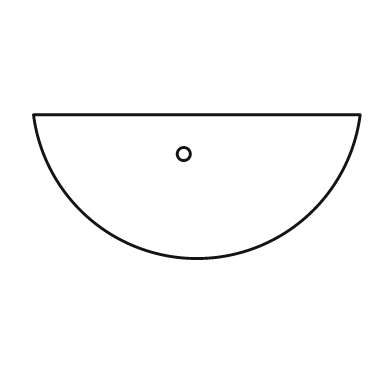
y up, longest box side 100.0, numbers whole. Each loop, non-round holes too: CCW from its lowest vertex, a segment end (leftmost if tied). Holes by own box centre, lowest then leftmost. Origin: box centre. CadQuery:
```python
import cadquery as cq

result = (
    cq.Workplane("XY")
    .moveTo(-50.0, 22.0)
    .threePointArc((0.0, -22.0), (50.0, 22.0))
    .close()
    .moveTo(-4.0, 10.0)
    .circle(2.0)
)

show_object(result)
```